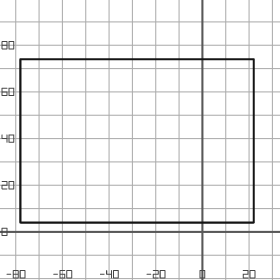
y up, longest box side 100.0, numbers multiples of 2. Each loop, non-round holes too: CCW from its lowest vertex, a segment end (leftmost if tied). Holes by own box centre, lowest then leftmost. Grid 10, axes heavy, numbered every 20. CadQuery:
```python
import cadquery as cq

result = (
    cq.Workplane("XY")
    .moveTo(-78.0, 4.0)
    .lineTo(22.0, 4.0)
    .lineTo(22.0, 74.0)
    .lineTo(-78.0, 74.0)
    .close()
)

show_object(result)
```